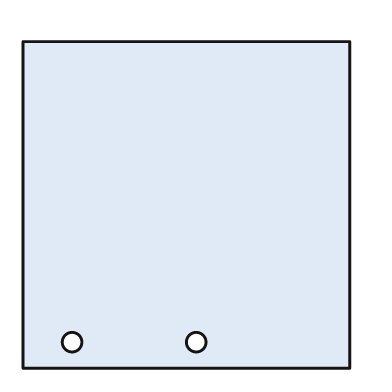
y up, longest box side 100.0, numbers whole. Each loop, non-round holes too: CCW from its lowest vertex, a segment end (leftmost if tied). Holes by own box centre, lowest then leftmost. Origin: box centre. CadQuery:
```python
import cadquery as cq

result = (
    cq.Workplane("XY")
    .moveTo(-50.0, -50.0)
    .lineTo(50.0, -50.0)
    .lineTo(50.0, 50.0)
    .lineTo(-50.0, 50.0)
    .close()
    .moveTo(-35.0, -42.0)
    .circle(3.0)
    .moveTo(3.0, -42.0)
    .circle(3.0)
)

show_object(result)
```